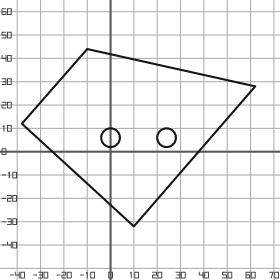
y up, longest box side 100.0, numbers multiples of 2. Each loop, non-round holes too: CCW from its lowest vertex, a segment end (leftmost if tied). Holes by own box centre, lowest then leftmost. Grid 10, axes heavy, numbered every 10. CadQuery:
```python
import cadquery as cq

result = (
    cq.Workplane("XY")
    .moveTo(10.0, -32.0)
    .lineTo(62.0, 28.0)
    .lineTo(-10.0, 44.0)
    .lineTo(-38.0, 12.0)
    .close()
    .moveTo(0.0, 6.0)
    .circle(4.0)
    .moveTo(24.0, 6.0)
    .circle(4.0)
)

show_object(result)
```